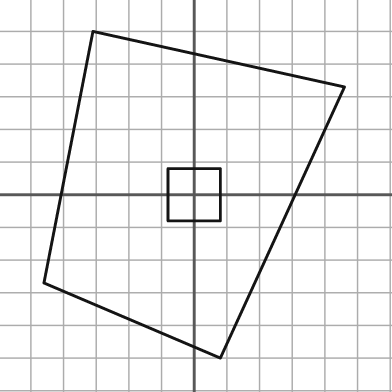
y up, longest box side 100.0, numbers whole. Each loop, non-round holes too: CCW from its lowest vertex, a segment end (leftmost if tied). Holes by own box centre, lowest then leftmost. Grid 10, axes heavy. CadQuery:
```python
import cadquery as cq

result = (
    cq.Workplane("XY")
    .moveTo(8.0, -50.0)
    .lineTo(46.0, 33.0)
    .lineTo(-31.0, 50.0)
    .lineTo(-46.0, -27.0)
    .close()
    .moveTo(-8.0, -8.0)
    .lineTo(8.0, -8.0)
    .lineTo(8.0, 8.0)
    .lineTo(-8.0, 8.0)
    .close()
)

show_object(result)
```